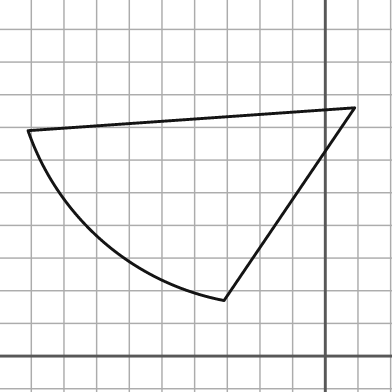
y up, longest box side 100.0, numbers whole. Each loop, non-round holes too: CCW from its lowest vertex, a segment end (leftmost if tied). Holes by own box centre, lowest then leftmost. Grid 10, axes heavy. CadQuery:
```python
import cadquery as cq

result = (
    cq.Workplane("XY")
    .moveTo(-31.0, 17.0)
    .lineTo(9.0, 76.0)
    .lineTo(-91.0, 69.0)
    .threePointArc((-68.0, 35.0), (-31.0, 17.0))
    .close()
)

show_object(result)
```